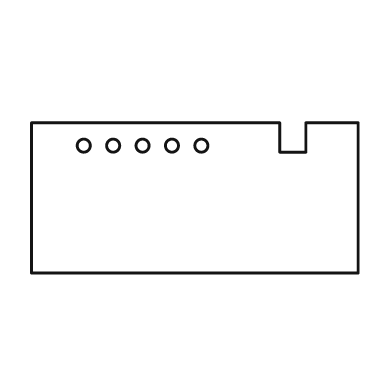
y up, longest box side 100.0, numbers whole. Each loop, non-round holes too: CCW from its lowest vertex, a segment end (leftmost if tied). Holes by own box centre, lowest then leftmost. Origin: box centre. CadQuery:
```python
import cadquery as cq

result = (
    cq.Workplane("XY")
    .moveTo(-50.0, -23.0)
    .lineTo(50.0, -23.0)
    .lineTo(50.0, 23.0)
    .lineTo(34.0, 23.0)
    .lineTo(34.0, 14.0)
    .lineTo(26.0, 14.0)
    .lineTo(26.0, 23.0)
    .lineTo(-50.0, 23.0)
    .close()
    .moveTo(-34.0, 16.0)
    .circle(2.0)
    .moveTo(-25.0, 16.0)
    .circle(2.0)
    .moveTo(-16.0, 16.0)
    .circle(2.0)
    .moveTo(-7.0, 16.0)
    .circle(2.0)
    .moveTo(2.0, 16.0)
    .circle(2.0)
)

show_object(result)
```